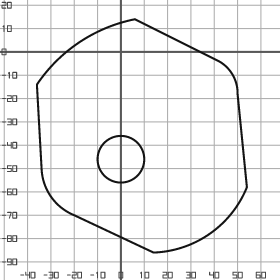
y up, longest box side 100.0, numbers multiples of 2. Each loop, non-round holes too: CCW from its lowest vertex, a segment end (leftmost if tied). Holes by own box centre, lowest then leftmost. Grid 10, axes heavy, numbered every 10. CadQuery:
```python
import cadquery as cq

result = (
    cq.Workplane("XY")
    .moveTo(14.0, -86.0)
    .threePointArc((38.0, -78.0), (54.0, -58.0))
    .lineTo(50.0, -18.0)
    .threePointArc((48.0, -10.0), (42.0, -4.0))
    .lineTo(6.0, 14.0)
    .threePointArc((-18.0, 4.0), (-36.0, -14.0))
    .lineTo(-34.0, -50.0)
    .threePointArc((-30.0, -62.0), (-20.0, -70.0))
    .close()
    .moveTo(0.0, -46.0)
    .circle(10.0)
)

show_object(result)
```